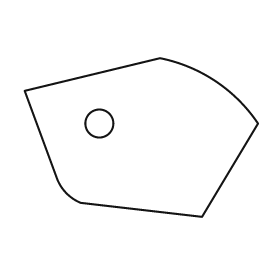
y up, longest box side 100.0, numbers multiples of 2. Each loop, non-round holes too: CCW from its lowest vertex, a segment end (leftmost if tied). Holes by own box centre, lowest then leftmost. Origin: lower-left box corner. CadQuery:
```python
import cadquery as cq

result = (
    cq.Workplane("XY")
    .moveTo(76.0, 0.0)
    .lineTo(100.0, 40.0)
    .threePointArc((82.0, 58.0), (58.0, 68.0))
    .lineTo(0.0, 54.0)
    .lineTo(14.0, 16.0)
    .threePointArc((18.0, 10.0), (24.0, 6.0))
    .close()
    .moveTo(32.0, 40.0)
    .circle(6.0)
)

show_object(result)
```